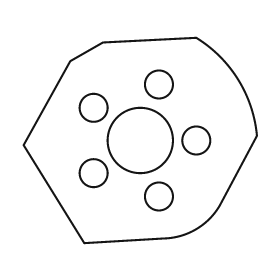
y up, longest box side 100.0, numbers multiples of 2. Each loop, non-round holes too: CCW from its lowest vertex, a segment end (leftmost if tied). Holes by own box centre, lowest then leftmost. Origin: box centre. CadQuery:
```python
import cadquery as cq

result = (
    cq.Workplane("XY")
    .moveTo(-24.0, -44.0)
    .lineTo(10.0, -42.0)
    .threePointArc((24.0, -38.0), (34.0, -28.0))
    .lineTo(50.0, 2.0)
    .threePointArc((42.0, 26.0), (24.0, 44.0))
    .lineTo(-16.0, 42.0)
    .lineTo(-30.0, 34.0)
    .lineTo(-50.0, -2.0)
    .close()
    .moveTo(8.0, -24.0)
    .circle(6.0)
    .moveTo(-20.0, -14.0)
    .circle(6.0)
    .moveTo(0.0, 0.0)
    .circle(14.0)
    .moveTo(24.0, 0.0)
    .circle(6.0)
    .moveTo(-20.0, 14.0)
    .circle(6.0)
    .moveTo(8.0, 24.0)
    .circle(6.0)
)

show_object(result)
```